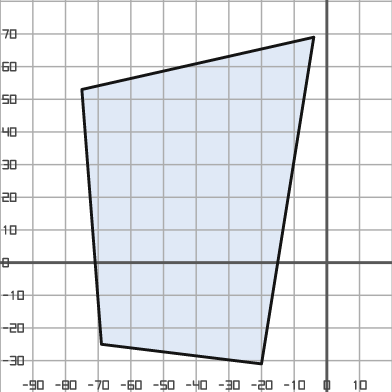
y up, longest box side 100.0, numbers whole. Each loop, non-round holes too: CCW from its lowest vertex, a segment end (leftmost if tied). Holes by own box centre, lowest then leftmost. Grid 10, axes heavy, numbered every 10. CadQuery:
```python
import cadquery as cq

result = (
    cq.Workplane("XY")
    .moveTo(-20.0, -31.0)
    .lineTo(-4.0, 69.0)
    .lineTo(-75.0, 53.0)
    .lineTo(-69.0, -25.0)
    .close()
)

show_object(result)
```